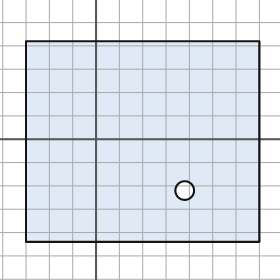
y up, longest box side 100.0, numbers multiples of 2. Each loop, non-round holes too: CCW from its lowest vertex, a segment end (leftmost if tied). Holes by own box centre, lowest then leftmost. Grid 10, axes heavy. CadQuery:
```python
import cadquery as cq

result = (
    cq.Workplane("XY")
    .moveTo(-30.0, -44.0)
    .lineTo(70.0, -44.0)
    .lineTo(70.0, 42.0)
    .lineTo(-30.0, 42.0)
    .close()
    .moveTo(38.0, -22.0)
    .circle(4.0)
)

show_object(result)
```